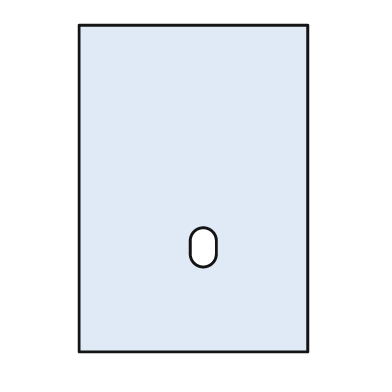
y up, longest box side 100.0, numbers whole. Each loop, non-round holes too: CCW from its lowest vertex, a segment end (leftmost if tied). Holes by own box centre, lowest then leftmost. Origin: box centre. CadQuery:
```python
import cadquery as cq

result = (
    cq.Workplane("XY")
    .moveTo(-35.0, -50.0)
    .lineTo(35.0, -50.0)
    .lineTo(35.0, 50.0)
    .lineTo(-35.0, 50.0)
    .close()
    .moveTo(-1.0, -20.0)
    .threePointArc((3.0, -24.0), (7.0, -20.0))
    .lineTo(7.0, -16.0)
    .threePointArc((3.0, -12.0), (-1.0, -16.0))
    .close()
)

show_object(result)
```